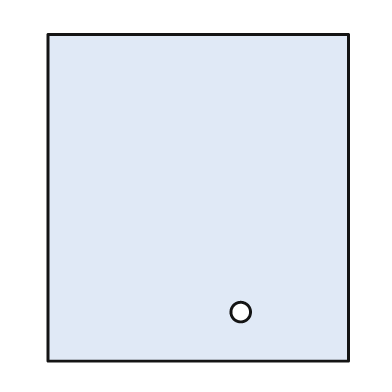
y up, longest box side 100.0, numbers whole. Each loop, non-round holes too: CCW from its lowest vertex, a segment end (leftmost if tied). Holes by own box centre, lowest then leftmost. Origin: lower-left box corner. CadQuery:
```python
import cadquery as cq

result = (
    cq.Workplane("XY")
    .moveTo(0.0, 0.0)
    .lineTo(92.0, 0.0)
    .lineTo(92.0, 100.0)
    .lineTo(0.0, 100.0)
    .close()
    .moveTo(59.0, 15.0)
    .circle(3.0)
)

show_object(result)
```